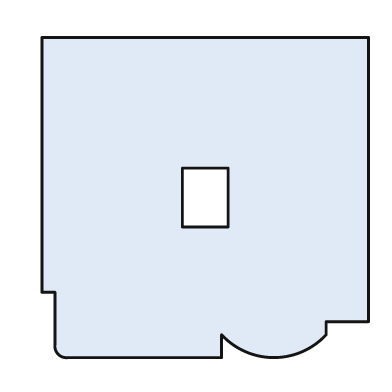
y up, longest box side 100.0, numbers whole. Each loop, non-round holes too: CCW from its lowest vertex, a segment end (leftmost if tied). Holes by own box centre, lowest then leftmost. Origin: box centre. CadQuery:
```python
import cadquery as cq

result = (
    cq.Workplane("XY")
    .moveTo(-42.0, -49.0)
    .lineTo(5.0, -49.0)
    .lineTo(5.0, -42.0)
    .threePointArc((21.0, -49.0), (37.0, -42.0))
    .lineTo(37.0, -38.0)
    .lineTo(50.0, -38.0)
    .lineTo(50.0, 49.0)
    .lineTo(-50.0, 49.0)
    .lineTo(-50.0, -29.0)
    .lineTo(-46.0, -29.0)
    .lineTo(-46.0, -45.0)
    .threePointArc((-45.0, -48.0), (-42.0, -49.0))
    .close()
    .moveTo(-7.0, -9.0)
    .lineTo(7.0, -9.0)
    .lineTo(7.0, 9.0)
    .lineTo(-7.0, 9.0)
    .close()
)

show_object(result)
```